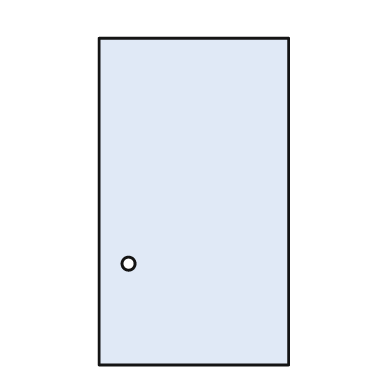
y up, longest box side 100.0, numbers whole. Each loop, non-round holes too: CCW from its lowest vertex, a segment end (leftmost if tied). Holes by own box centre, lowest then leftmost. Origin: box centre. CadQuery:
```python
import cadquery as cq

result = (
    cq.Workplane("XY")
    .moveTo(-29.0, -50.0)
    .lineTo(29.0, -50.0)
    .lineTo(29.0, 50.0)
    .lineTo(-29.0, 50.0)
    .close()
    .moveTo(-20.0, -19.0)
    .circle(2.0)
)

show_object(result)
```